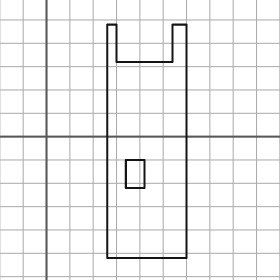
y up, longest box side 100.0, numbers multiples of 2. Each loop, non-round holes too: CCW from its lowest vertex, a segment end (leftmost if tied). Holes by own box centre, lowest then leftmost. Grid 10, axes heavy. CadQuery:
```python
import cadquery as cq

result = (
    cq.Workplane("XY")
    .moveTo(26.0, -52.0)
    .lineTo(60.0, -52.0)
    .lineTo(60.0, 48.0)
    .lineTo(54.0, 48.0)
    .lineTo(54.0, 32.0)
    .lineTo(30.0, 32.0)
    .lineTo(30.0, 48.0)
    .lineTo(26.0, 48.0)
    .close()
    .moveTo(34.0, -22.0)
    .lineTo(42.0, -22.0)
    .lineTo(42.0, -10.0)
    .lineTo(34.0, -10.0)
    .close()
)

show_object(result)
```